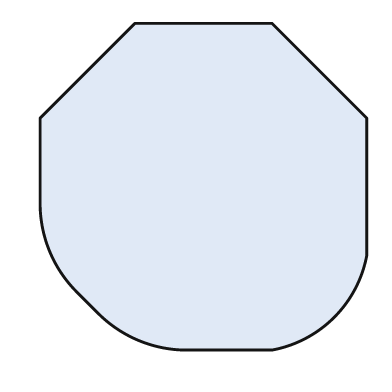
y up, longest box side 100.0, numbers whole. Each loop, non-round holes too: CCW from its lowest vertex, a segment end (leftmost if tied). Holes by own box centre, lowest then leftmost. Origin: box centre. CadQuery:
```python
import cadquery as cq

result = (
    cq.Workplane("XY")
    .moveTo(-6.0, -50.0)
    .lineTo(21.0, -50.0)
    .threePointArc((40.0, -40.0), (50.0, -21.0))
    .lineTo(50.0, 21.0)
    .lineTo(21.0, 50.0)
    .lineTo(-21.0, 50.0)
    .lineTo(-50.0, 21.0)
    .lineTo(-50.0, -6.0)
    .threePointArc((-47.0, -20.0), (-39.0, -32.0))
    .lineTo(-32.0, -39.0)
    .threePointArc((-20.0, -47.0), (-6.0, -50.0))
    .close()
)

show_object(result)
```